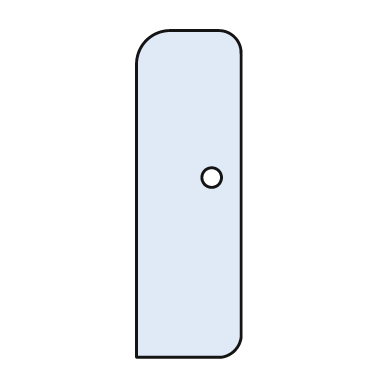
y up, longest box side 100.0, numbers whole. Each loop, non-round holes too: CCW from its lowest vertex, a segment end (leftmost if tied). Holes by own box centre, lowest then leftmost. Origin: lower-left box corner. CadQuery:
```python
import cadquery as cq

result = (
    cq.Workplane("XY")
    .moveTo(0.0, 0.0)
    .lineTo(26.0, 0.0)
    .threePointArc((30.0, 2.0), (32.0, 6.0))
    .lineTo(32.0, 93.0)
    .threePointArc((30.0, 98.0), (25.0, 100.0))
    .lineTo(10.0, 100.0)
    .threePointArc((3.0, 97.0), (0.0, 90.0))
    .close()
    .moveTo(23.0, 55.0)
    .circle(3.0)
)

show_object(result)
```